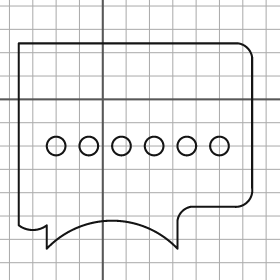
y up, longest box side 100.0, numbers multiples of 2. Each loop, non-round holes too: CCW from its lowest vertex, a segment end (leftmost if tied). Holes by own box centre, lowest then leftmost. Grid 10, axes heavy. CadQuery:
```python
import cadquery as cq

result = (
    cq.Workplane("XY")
    .moveTo(-24.0, -64.0)
    .threePointArc((4.0, -52.0), (32.0, -64.0))
    .lineTo(32.0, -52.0)
    .threePointArc((34.0, -48.0), (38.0, -46.0))
    .lineTo(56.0, -46.0)
    .threePointArc((62.0, -44.0), (64.0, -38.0))
    .lineTo(64.0, 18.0)
    .threePointArc((62.0, 22.0), (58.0, 24.0))
    .lineTo(-36.0, 24.0)
    .lineTo(-36.0, -54.0)
    .threePointArc((-30.0, -56.0), (-24.0, -54.0))
    .close()
    .moveTo(-20.0, -20.0)
    .circle(4.0)
    .moveTo(-6.0, -20.0)
    .circle(4.0)
    .moveTo(8.0, -20.0)
    .circle(4.0)
    .moveTo(22.0, -20.0)
    .circle(4.0)
    .moveTo(36.0, -20.0)
    .circle(4.0)
    .moveTo(50.0, -20.0)
    .circle(4.0)
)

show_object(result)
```